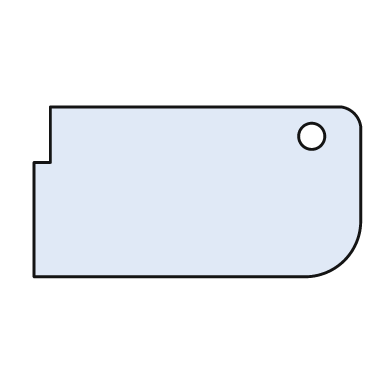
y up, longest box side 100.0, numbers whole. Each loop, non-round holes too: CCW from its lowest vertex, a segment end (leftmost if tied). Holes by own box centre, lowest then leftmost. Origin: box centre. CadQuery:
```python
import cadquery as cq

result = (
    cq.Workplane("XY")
    .moveTo(-50.0, -26.0)
    .lineTo(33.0, -26.0)
    .threePointArc((45.0, -21.0), (50.0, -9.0))
    .lineTo(50.0, 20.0)
    .threePointArc((48.0, 24.0), (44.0, 26.0))
    .lineTo(-45.0, 26.0)
    .lineTo(-45.0, 9.0)
    .lineTo(-50.0, 9.0)
    .close()
    .moveTo(35.0, 17.0)
    .circle(4.0)
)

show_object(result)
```